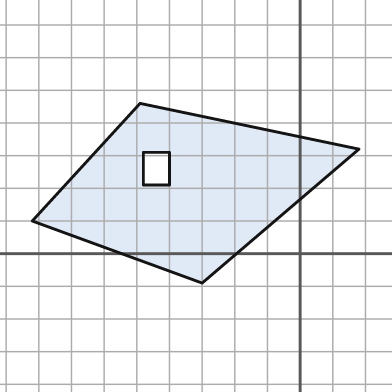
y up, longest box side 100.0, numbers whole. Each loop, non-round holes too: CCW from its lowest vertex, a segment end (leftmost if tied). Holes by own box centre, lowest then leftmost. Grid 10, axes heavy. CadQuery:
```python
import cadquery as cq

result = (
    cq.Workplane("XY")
    .moveTo(-30.0, -9.0)
    .lineTo(18.0, 32.0)
    .lineTo(-49.0, 46.0)
    .lineTo(-82.0, 10.0)
    .close()
    .moveTo(-48.0, 21.0)
    .lineTo(-40.0, 21.0)
    .lineTo(-40.0, 31.0)
    .lineTo(-48.0, 31.0)
    .close()
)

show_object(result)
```